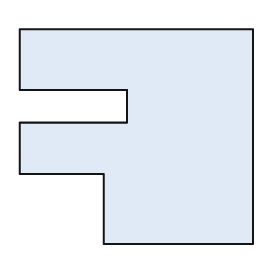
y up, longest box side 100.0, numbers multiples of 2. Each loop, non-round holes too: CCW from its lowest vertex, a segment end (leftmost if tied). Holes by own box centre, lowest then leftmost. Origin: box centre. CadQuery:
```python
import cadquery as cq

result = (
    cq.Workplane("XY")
    .moveTo(-14.0, -46.0)
    .lineTo(50.0, -46.0)
    .lineTo(50.0, 46.0)
    .lineTo(-50.0, 46.0)
    .lineTo(-50.0, 20.0)
    .lineTo(-4.0, 20.0)
    .lineTo(-4.0, 6.0)
    .lineTo(-50.0, 6.0)
    .lineTo(-50.0, -16.0)
    .lineTo(-14.0, -16.0)
    .close()
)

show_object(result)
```